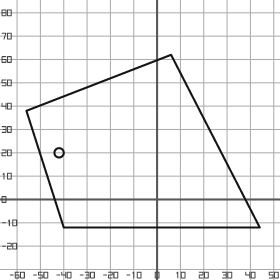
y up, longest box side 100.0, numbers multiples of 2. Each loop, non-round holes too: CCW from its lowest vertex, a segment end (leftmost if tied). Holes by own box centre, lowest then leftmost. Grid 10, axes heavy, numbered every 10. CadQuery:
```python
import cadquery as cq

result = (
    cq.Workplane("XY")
    .moveTo(-40.0, -12.0)
    .lineTo(44.0, -12.0)
    .lineTo(6.0, 62.0)
    .lineTo(-56.0, 38.0)
    .close()
    .moveTo(-42.0, 20.0)
    .circle(2.0)
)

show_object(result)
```